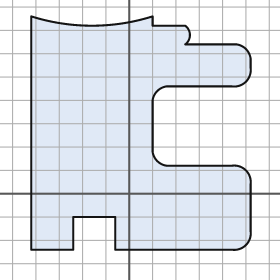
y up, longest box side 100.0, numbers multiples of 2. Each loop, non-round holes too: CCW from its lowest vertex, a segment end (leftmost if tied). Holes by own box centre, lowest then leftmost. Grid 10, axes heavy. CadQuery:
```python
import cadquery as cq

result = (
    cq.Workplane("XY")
    .moveTo(-42.0, -24.0)
    .lineTo(-24.0, -24.0)
    .lineTo(-24.0, -10.0)
    .lineTo(-6.0, -10.0)
    .lineTo(-6.0, -24.0)
    .lineTo(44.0, -24.0)
    .threePointArc((50.0, -22.0), (52.0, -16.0))
    .lineTo(52.0, 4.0)
    .threePointArc((50.0, 10.0), (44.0, 12.0))
    .lineTo(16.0, 12.0)
    .threePointArc((12.0, 14.0), (10.0, 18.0))
    .lineTo(10.0, 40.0)
    .threePointArc((12.0, 44.0), (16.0, 46.0))
    .lineTo(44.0, 46.0)
    .threePointArc((50.0, 48.0), (52.0, 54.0))
    .lineTo(52.0, 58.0)
    .threePointArc((50.0, 62.0), (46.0, 64.0))
    .lineTo(24.0, 64.0)
    .threePointArc((26.0, 68.0), (24.0, 72.0))
    .lineTo(10.0, 72.0)
    .lineTo(10.0, 76.0)
    .threePointArc((-16.0, 72.0), (-42.0, 76.0))
    .close()
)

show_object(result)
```